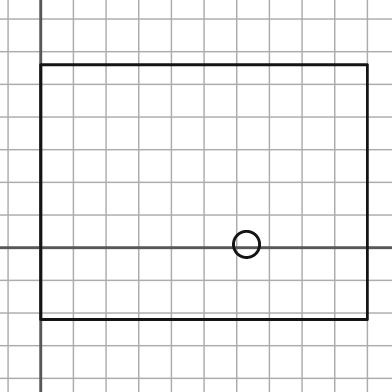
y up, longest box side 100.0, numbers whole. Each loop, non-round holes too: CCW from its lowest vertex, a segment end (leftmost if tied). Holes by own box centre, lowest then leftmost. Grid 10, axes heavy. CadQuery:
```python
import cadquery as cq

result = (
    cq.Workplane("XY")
    .moveTo(0.0, -22.0)
    .lineTo(100.0, -22.0)
    .lineTo(100.0, 56.0)
    .lineTo(0.0, 56.0)
    .close()
    .moveTo(63.0, 1.0)
    .circle(4.0)
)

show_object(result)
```